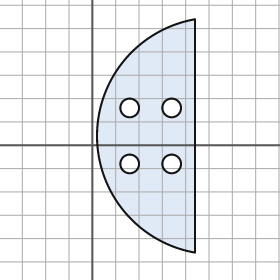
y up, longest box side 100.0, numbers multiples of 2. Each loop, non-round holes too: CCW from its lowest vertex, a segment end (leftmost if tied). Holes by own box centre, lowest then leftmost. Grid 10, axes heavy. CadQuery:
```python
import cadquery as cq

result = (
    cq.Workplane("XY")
    .moveTo(44.0, -46.0)
    .lineTo(44.0, 54.0)
    .threePointArc((2.0, 4.0), (44.0, -46.0))
    .close()
    .moveTo(16.0, -8.0)
    .circle(4.0)
    .moveTo(34.0, -8.0)
    .circle(4.0)
    .moveTo(16.0, 16.0)
    .circle(4.0)
    .moveTo(34.0, 16.0)
    .circle(4.0)
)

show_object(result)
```